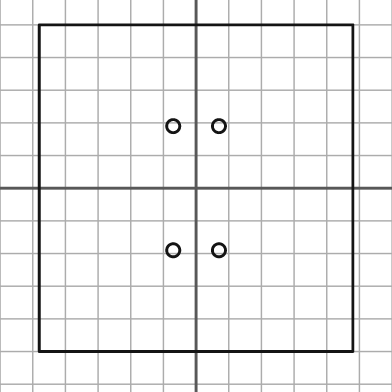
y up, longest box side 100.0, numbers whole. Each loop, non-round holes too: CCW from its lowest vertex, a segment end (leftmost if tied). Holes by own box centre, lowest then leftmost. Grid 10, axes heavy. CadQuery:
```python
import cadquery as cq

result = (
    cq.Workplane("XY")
    .moveTo(-48.0, -50.0)
    .lineTo(48.0, -50.0)
    .lineTo(48.0, 50.0)
    .lineTo(-48.0, 50.0)
    .close()
    .moveTo(-7.0, -19.0)
    .circle(2.0)
    .moveTo(7.0, -19.0)
    .circle(2.0)
    .moveTo(-7.0, 19.0)
    .circle(2.0)
    .moveTo(7.0, 19.0)
    .circle(2.0)
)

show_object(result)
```